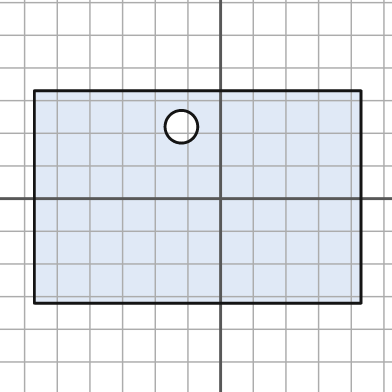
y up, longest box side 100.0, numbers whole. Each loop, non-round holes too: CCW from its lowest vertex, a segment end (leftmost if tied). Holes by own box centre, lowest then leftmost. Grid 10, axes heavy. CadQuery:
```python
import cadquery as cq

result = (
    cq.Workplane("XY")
    .moveTo(-57.0, -32.0)
    .lineTo(43.0, -32.0)
    .lineTo(43.0, 33.0)
    .lineTo(-57.0, 33.0)
    .close()
    .moveTo(-12.0, 22.0)
    .circle(5.0)
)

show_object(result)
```